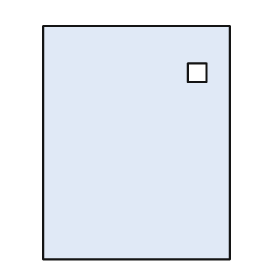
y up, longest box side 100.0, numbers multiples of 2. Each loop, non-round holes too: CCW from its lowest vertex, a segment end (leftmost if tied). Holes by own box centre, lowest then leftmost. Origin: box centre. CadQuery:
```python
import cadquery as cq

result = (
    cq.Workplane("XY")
    .moveTo(-40.0, -50.0)
    .lineTo(40.0, -50.0)
    .lineTo(40.0, 50.0)
    .lineTo(-40.0, 50.0)
    .close()
    .moveTo(22.0, 26.0)
    .lineTo(30.0, 26.0)
    .lineTo(30.0, 34.0)
    .lineTo(22.0, 34.0)
    .close()
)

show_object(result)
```